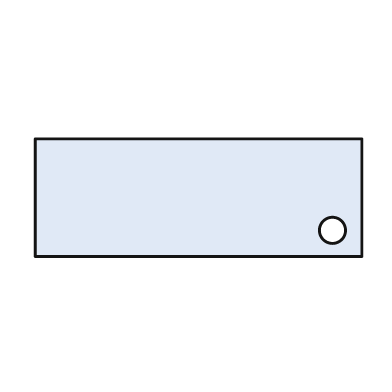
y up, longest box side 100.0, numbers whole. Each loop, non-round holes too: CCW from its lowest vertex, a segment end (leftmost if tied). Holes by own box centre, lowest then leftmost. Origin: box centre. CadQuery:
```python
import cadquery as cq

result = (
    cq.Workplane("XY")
    .moveTo(-50.0, -18.0)
    .lineTo(50.0, -18.0)
    .lineTo(50.0, 18.0)
    .lineTo(-50.0, 18.0)
    .close()
    .moveTo(41.0, -10.0)
    .circle(4.0)
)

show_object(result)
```